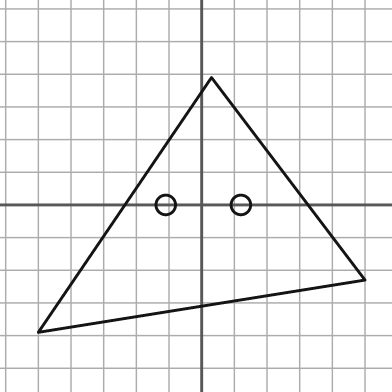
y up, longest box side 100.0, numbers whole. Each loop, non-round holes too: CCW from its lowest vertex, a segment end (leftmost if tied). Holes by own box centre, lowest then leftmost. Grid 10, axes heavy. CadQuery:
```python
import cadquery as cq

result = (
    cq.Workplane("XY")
    .moveTo(-50.0, -39.0)
    .lineTo(50.0, -23.0)
    .lineTo(3.0, 39.0)
    .close()
    .moveTo(-11.0, 0.0)
    .circle(3.0)
    .moveTo(12.0, 0.0)
    .circle(3.0)
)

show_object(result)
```